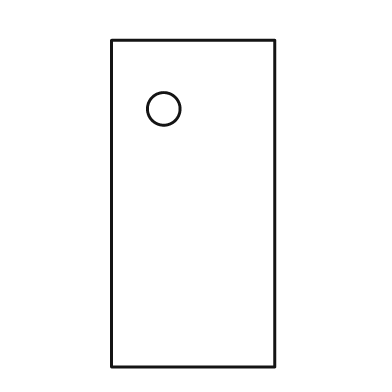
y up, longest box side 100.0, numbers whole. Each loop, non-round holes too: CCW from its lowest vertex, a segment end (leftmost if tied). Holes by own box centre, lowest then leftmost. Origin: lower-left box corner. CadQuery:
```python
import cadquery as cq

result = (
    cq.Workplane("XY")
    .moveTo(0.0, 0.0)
    .lineTo(50.0, 0.0)
    .lineTo(50.0, 100.0)
    .lineTo(0.0, 100.0)
    .close()
    .moveTo(16.0, 79.0)
    .circle(5.0)
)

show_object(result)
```